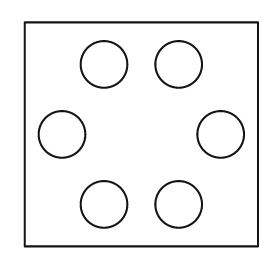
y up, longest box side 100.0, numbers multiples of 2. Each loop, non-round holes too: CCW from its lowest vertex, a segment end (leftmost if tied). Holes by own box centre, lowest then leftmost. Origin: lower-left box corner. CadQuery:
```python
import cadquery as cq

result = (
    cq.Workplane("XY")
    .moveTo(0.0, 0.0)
    .lineTo(100.0, 0.0)
    .lineTo(100.0, 96.0)
    .lineTo(0.0, 96.0)
    .close()
    .moveTo(34.0, 18.0)
    .circle(10.0)
    .moveTo(66.0, 18.0)
    .circle(10.0)
    .moveTo(16.0, 48.0)
    .circle(10.0)
    .moveTo(84.0, 48.0)
    .circle(10.0)
    .moveTo(34.0, 78.0)
    .circle(10.0)
    .moveTo(66.0, 78.0)
    .circle(10.0)
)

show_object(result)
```